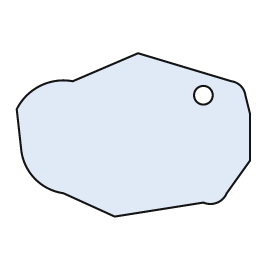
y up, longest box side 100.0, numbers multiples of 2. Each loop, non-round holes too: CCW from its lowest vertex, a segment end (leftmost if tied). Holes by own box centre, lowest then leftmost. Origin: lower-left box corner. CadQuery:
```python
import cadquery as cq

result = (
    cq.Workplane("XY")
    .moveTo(42.0, 0.0)
    .lineTo(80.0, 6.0)
    .threePointArc((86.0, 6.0), (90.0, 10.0))
    .lineTo(100.0, 24.0)
    .lineTo(100.0, 44.0)
    .lineTo(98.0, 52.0)
    .threePointArc((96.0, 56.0), (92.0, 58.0))
    .lineTo(52.0, 70.0)
    .lineTo(24.0, 58.0)
    .threePointArc((10.0, 56.0), (0.0, 46.0))
    .lineTo(2.0, 28.0)
    .threePointArc((8.0, 16.0), (20.0, 10.0))
    .close()
    .moveTo(80.0, 52.0)
    .circle(4.0)
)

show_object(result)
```